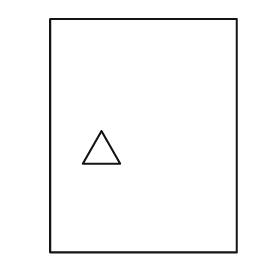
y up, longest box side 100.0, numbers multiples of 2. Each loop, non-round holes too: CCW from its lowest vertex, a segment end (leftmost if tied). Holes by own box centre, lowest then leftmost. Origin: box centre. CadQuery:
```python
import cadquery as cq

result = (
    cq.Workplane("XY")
    .moveTo(-40.0, -50.0)
    .lineTo(40.0, -50.0)
    .lineTo(40.0, 50.0)
    .lineTo(-40.0, 50.0)
    .close()
    .moveTo(-26.0, -12.0)
    .lineTo(-10.0, -12.0)
    .lineTo(-18.0, 2.0)
    .close()
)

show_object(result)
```